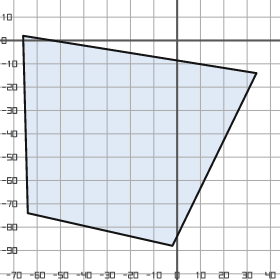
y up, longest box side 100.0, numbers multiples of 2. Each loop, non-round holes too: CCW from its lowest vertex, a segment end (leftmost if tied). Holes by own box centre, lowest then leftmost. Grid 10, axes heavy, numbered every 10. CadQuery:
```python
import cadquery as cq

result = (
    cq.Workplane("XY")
    .moveTo(-2.0, -88.0)
    .lineTo(34.0, -14.0)
    .lineTo(-66.0, 2.0)
    .lineTo(-64.0, -74.0)
    .close()
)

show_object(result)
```